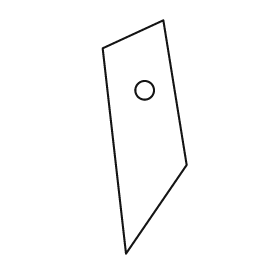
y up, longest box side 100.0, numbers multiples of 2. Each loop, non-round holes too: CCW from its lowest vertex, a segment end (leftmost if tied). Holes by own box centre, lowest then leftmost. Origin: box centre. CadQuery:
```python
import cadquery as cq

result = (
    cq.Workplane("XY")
    .moveTo(-8.0, -50.0)
    .lineTo(18.0, -12.0)
    .lineTo(8.0, 50.0)
    .lineTo(-18.0, 38.0)
    .close()
    .moveTo(0.0, 20.0)
    .circle(4.0)
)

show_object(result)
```